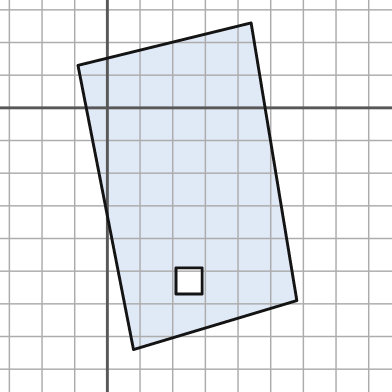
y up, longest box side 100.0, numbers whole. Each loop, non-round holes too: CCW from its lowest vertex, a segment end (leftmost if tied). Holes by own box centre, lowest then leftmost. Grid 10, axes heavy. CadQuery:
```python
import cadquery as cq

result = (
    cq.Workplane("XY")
    .moveTo(8.0, -74.0)
    .lineTo(58.0, -59.0)
    .lineTo(44.0, 26.0)
    .lineTo(-9.0, 13.0)
    .close()
    .moveTo(21.0, -57.0)
    .lineTo(29.0, -57.0)
    .lineTo(29.0, -49.0)
    .lineTo(21.0, -49.0)
    .close()
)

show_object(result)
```